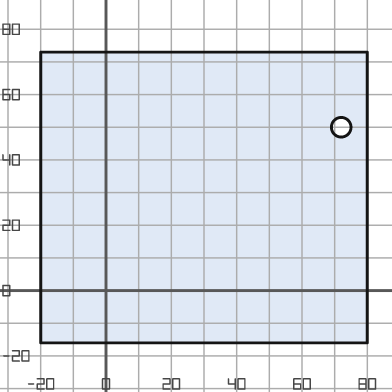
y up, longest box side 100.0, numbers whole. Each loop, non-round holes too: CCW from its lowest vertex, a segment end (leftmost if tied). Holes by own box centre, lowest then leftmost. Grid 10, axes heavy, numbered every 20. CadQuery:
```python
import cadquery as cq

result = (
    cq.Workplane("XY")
    .moveTo(-20.0, -16.0)
    .lineTo(80.0, -16.0)
    .lineTo(80.0, 73.0)
    .lineTo(-20.0, 73.0)
    .close()
    .moveTo(72.0, 50.0)
    .circle(3.0)
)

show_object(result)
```